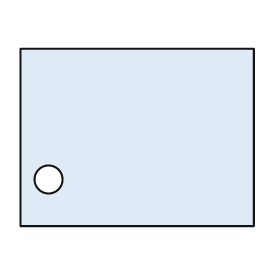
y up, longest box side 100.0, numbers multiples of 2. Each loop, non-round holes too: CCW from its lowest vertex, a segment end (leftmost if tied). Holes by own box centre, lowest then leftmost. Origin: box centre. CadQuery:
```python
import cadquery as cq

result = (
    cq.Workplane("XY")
    .moveTo(-50.0, -38.0)
    .lineTo(50.0, -38.0)
    .lineTo(50.0, 38.0)
    .lineTo(-50.0, 38.0)
    .close()
    .moveTo(-38.0, -18.0)
    .circle(6.0)
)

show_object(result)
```